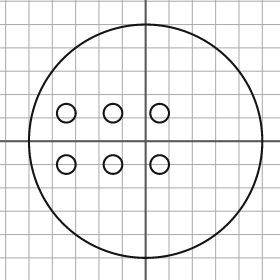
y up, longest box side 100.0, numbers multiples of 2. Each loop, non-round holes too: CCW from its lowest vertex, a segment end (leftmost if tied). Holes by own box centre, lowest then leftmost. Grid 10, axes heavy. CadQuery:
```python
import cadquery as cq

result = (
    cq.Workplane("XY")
    .moveTo(0.0, 0.0)
    .circle(50.0)
    .moveTo(-34.0, -10.0)
    .circle(4.0)
    .moveTo(-14.0, -10.0)
    .circle(4.0)
    .moveTo(6.0, -10.0)
    .circle(4.0)
    .moveTo(-34.0, 12.0)
    .circle(4.0)
    .moveTo(-14.0, 12.0)
    .circle(4.0)
    .moveTo(6.0, 12.0)
    .circle(4.0)
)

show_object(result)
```